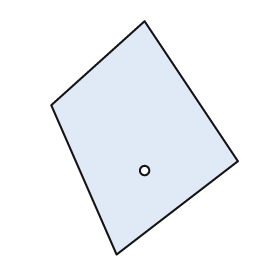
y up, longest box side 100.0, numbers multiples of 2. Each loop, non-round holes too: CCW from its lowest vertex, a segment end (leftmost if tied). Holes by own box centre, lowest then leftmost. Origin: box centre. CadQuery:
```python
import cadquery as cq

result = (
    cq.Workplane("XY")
    .moveTo(-12.0, -50.0)
    .lineTo(40.0, -10.0)
    .lineTo(0.0, 50.0)
    .lineTo(-40.0, 14.0)
    .close()
    .moveTo(0.0, -14.0)
    .circle(2.0)
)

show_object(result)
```